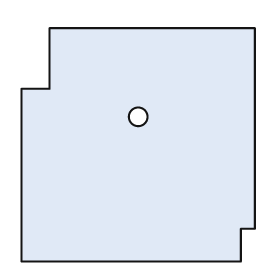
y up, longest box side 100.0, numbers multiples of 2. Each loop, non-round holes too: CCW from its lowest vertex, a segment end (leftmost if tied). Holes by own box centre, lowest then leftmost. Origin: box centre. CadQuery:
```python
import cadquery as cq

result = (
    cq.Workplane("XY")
    .moveTo(-50.0, -50.0)
    .lineTo(44.0, -50.0)
    .lineTo(44.0, -36.0)
    .lineTo(50.0, -36.0)
    .lineTo(50.0, 50.0)
    .lineTo(-38.0, 50.0)
    .lineTo(-38.0, 24.0)
    .lineTo(-50.0, 24.0)
    .close()
    .moveTo(0.0, 12.0)
    .circle(4.0)
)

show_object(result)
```